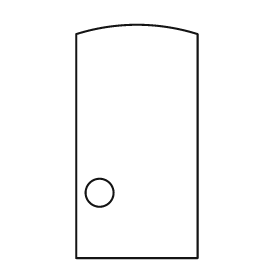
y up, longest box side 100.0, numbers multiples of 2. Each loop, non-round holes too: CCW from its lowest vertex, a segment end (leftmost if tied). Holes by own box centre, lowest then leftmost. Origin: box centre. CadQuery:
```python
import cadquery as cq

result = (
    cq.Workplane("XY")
    .moveTo(-26.0, -50.0)
    .lineTo(26.0, -50.0)
    .lineTo(26.0, 46.0)
    .threePointArc((0.0, 50.0), (-26.0, 46.0))
    .close()
    .moveTo(-16.0, -22.0)
    .circle(6.0)
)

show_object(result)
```